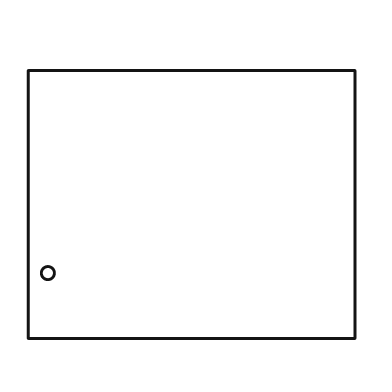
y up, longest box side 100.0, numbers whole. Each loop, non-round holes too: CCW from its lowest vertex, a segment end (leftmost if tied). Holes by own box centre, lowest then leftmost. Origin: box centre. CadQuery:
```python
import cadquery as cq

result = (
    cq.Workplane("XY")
    .moveTo(-50.0, -41.0)
    .lineTo(50.0, -41.0)
    .lineTo(50.0, 41.0)
    .lineTo(-50.0, 41.0)
    .close()
    .moveTo(-44.0, -21.0)
    .circle(2.0)
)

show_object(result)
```